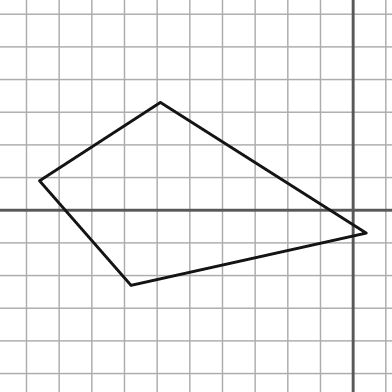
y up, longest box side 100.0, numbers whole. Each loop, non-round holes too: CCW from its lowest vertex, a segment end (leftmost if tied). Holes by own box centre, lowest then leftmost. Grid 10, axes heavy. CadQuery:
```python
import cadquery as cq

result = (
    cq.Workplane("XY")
    .moveTo(-68.0, -23.0)
    .lineTo(4.0, -7.0)
    .lineTo(-59.0, 33.0)
    .lineTo(-96.0, 9.0)
    .close()
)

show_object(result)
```